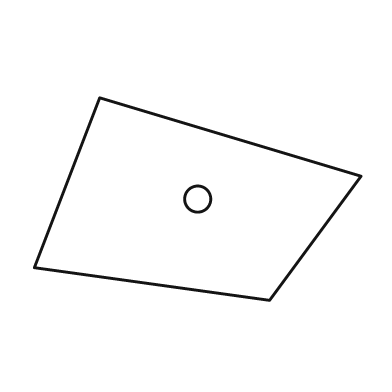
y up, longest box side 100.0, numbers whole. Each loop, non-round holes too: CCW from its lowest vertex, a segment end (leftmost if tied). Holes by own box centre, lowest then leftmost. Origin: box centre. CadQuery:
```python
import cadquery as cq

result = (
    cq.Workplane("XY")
    .moveTo(22.0, -31.0)
    .lineTo(50.0, 7.0)
    .lineTo(-30.0, 31.0)
    .lineTo(-50.0, -21.0)
    .close()
    .moveTo(0.0, 0.0)
    .circle(4.0)
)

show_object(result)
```